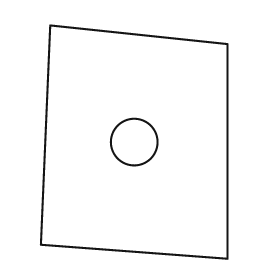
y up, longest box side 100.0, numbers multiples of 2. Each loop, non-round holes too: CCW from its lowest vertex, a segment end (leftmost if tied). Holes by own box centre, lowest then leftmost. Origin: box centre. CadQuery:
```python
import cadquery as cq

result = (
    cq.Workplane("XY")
    .moveTo(40.0, -50.0)
    .lineTo(40.0, 42.0)
    .lineTo(-36.0, 50.0)
    .lineTo(-40.0, -44.0)
    .close()
    .moveTo(0.0, 0.0)
    .circle(10.0)
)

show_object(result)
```